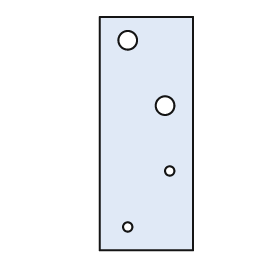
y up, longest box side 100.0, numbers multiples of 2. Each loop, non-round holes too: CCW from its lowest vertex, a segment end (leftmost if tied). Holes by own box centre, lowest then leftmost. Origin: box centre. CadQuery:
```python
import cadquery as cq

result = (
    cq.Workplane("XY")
    .moveTo(-20.0, -50.0)
    .lineTo(20.0, -50.0)
    .lineTo(20.0, 50.0)
    .lineTo(-20.0, 50.0)
    .close()
    .moveTo(-8.0, -40.0)
    .circle(2.0)
    .moveTo(10.0, -16.0)
    .circle(2.0)
    .moveTo(8.0, 12.0)
    .circle(4.0)
    .moveTo(-8.0, 40.0)
    .circle(4.0)
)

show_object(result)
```